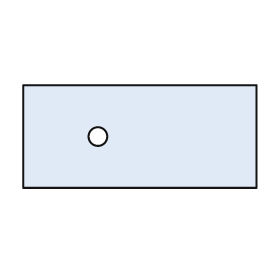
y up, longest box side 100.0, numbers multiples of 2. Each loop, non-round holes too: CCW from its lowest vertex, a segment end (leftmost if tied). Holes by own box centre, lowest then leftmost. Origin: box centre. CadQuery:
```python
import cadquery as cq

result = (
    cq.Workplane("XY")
    .moveTo(-50.0, -22.0)
    .lineTo(50.0, -22.0)
    .lineTo(50.0, 22.0)
    .lineTo(-50.0, 22.0)
    .close()
    .moveTo(-18.0, 0.0)
    .circle(4.0)
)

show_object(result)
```